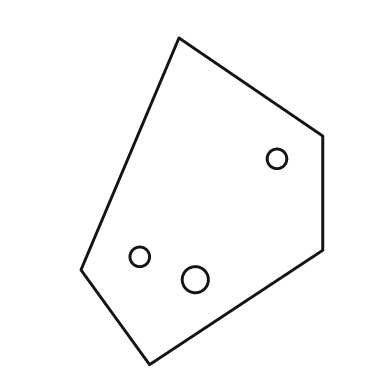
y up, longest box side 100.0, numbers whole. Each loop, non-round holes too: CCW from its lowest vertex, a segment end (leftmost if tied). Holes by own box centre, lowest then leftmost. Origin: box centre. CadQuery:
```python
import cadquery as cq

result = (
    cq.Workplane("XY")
    .moveTo(-16.0, -50.0)
    .lineTo(37.0, -15.0)
    .lineTo(37.0, 20.0)
    .lineTo(-7.0, 50.0)
    .lineTo(-37.0, -21.0)
    .close()
    .moveTo(-2.0, -24.0)
    .circle(4.0)
    .moveTo(-19.0, -17.0)
    .circle(3.0)
    .moveTo(23.0, 13.0)
    .circle(3.0)
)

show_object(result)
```